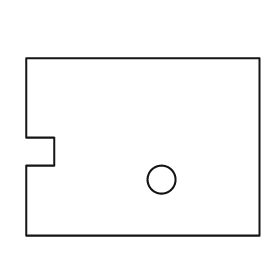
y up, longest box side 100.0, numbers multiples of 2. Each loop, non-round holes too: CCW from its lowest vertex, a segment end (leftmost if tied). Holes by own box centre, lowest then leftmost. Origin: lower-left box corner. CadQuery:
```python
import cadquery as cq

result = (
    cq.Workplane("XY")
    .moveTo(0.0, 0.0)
    .lineTo(100.0, 0.0)
    .lineTo(100.0, 76.0)
    .lineTo(0.0, 76.0)
    .lineTo(0.0, 42.0)
    .lineTo(12.0, 42.0)
    .lineTo(12.0, 30.0)
    .lineTo(0.0, 30.0)
    .close()
    .moveTo(58.0, 24.0)
    .circle(6.0)
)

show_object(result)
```